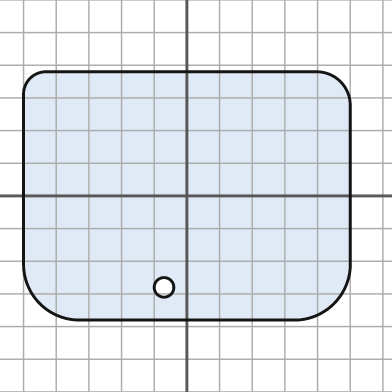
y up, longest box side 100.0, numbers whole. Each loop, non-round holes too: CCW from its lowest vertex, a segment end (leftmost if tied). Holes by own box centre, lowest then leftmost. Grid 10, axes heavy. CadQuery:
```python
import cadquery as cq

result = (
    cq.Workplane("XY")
    .moveTo(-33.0, -38.0)
    .lineTo(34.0, -38.0)
    .threePointArc((45.0, -33.0), (50.0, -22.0))
    .lineTo(50.0, 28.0)
    .threePointArc((47.0, 35.0), (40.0, 38.0))
    .lineTo(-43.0, 38.0)
    .threePointArc((-48.0, 36.0), (-50.0, 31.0))
    .lineTo(-50.0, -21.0)
    .threePointArc((-45.0, -33.0), (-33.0, -38.0))
    .close()
    .moveTo(-7.0, -28.0)
    .circle(3.0)
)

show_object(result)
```